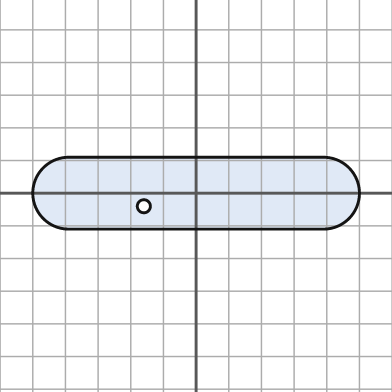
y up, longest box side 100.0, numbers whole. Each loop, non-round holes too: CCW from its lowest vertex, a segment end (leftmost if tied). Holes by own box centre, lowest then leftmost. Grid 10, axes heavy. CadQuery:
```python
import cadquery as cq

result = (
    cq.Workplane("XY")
    .moveTo(-39.0, -11.0)
    .lineTo(39.0, -11.0)
    .threePointArc((50.0, 0.0), (39.0, 11.0))
    .lineTo(-39.0, 11.0)
    .threePointArc((-50.0, 0.0), (-39.0, -11.0))
    .close()
    .moveTo(-16.0, -4.0)
    .circle(2.0)
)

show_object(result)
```